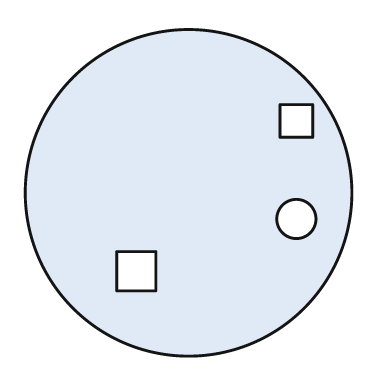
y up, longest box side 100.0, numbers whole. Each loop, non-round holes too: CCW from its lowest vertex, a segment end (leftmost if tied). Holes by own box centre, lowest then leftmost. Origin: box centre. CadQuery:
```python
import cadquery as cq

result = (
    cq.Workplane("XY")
    .moveTo(0.0, 0.0)
    .circle(50.0)
    .moveTo(-22.0, -30.0)
    .lineTo(-10.0, -30.0)
    .lineTo(-10.0, -18.0)
    .lineTo(-22.0, -18.0)
    .close()
    .moveTo(33.0, -8.0)
    .circle(6.0)
    .moveTo(28.0, 17.0)
    .lineTo(38.0, 17.0)
    .lineTo(38.0, 27.0)
    .lineTo(28.0, 27.0)
    .close()
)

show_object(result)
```